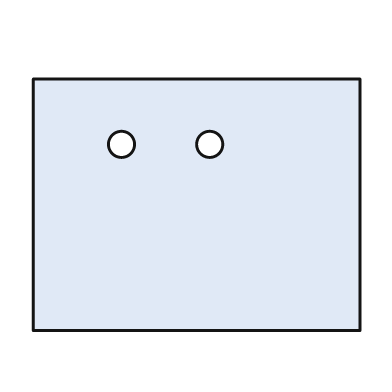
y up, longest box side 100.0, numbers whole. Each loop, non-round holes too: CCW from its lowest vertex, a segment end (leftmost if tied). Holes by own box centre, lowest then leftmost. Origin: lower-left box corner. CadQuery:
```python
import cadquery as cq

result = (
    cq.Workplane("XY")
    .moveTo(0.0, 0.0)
    .lineTo(100.0, 0.0)
    .lineTo(100.0, 77.0)
    .lineTo(0.0, 77.0)
    .close()
    .moveTo(27.0, 57.0)
    .circle(4.0)
    .moveTo(54.0, 57.0)
    .circle(4.0)
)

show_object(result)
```